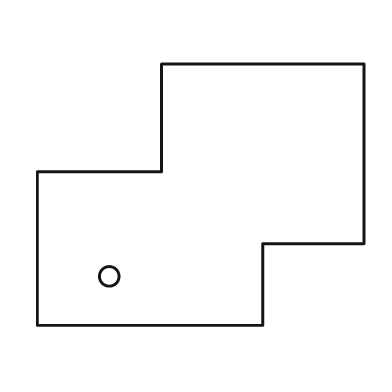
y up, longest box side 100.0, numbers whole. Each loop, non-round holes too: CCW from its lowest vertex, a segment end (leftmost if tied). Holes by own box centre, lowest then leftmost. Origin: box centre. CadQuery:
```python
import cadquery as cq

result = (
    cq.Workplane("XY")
    .moveTo(-50.0, -40.0)
    .lineTo(19.0, -40.0)
    .lineTo(19.0, -15.0)
    .lineTo(50.0, -15.0)
    .lineTo(50.0, 40.0)
    .lineTo(-12.0, 40.0)
    .lineTo(-12.0, 7.0)
    .lineTo(-50.0, 7.0)
    .close()
    .moveTo(-28.0, -25.0)
    .circle(3.0)
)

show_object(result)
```